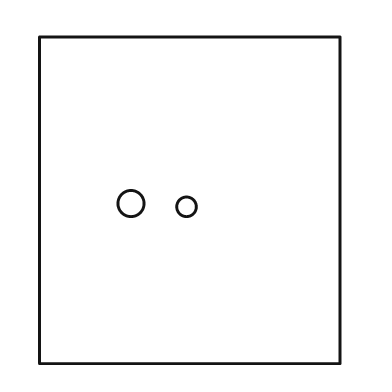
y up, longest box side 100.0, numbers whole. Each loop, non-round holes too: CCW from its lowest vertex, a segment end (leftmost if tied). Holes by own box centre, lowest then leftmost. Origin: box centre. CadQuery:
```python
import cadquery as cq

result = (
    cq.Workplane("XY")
    .moveTo(-46.0, -50.0)
    .lineTo(46.0, -50.0)
    .lineTo(46.0, 50.0)
    .lineTo(-46.0, 50.0)
    .close()
    .moveTo(-1.0, -2.0)
    .circle(3.0)
    .moveTo(-18.0, -1.0)
    .circle(4.0)
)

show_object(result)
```